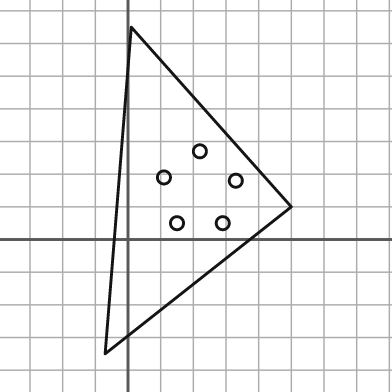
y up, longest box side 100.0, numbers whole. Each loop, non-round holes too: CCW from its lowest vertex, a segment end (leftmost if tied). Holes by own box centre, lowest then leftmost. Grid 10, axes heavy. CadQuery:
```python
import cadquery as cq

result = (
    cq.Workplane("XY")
    .moveTo(-7.0, -35.0)
    .lineTo(50.0, 10.0)
    .lineTo(1.0, 65.0)
    .close()
    .moveTo(15.0, 5.0)
    .circle(2.0)
    .moveTo(29.0, 5.0)
    .circle(2.0)
    .moveTo(33.0, 18.0)
    .circle(2.0)
    .moveTo(11.0, 19.0)
    .circle(2.0)
    .moveTo(22.0, 27.0)
    .circle(2.0)
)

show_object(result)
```